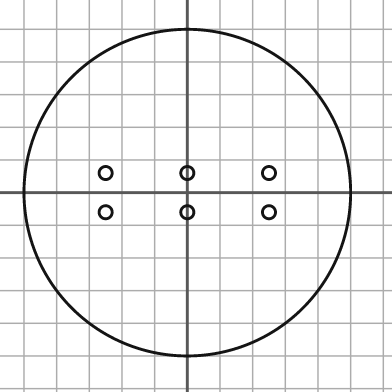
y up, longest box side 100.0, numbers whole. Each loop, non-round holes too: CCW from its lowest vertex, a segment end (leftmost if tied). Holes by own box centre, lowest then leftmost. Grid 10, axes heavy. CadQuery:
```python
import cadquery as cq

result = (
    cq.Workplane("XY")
    .moveTo(0.0, 0.0)
    .circle(50.0)
    .moveTo(-25.0, -6.0)
    .circle(2.0)
    .moveTo(0.0, -6.0)
    .circle(2.0)
    .moveTo(25.0, -6.0)
    .circle(2.0)
    .moveTo(-25.0, 6.0)
    .circle(2.0)
    .moveTo(0.0, 6.0)
    .circle(2.0)
    .moveTo(25.0, 6.0)
    .circle(2.0)
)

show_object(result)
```